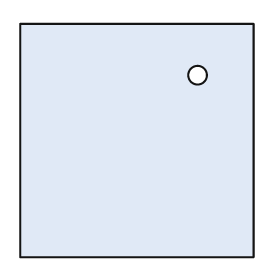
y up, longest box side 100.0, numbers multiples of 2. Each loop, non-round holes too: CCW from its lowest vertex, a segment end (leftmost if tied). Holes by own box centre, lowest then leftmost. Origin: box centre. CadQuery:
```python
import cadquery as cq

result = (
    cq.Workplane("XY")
    .moveTo(-50.0, -50.0)
    .lineTo(50.0, -50.0)
    .lineTo(50.0, 50.0)
    .lineTo(-50.0, 50.0)
    .close()
    .moveTo(26.0, 28.0)
    .circle(4.0)
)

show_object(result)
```